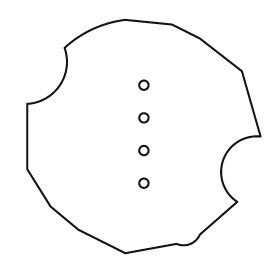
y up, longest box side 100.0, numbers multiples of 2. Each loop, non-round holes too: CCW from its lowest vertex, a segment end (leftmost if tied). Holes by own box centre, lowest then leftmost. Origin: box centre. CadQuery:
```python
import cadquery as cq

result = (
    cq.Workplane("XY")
    .moveTo(-8.0, -50.0)
    .lineTo(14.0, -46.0)
    .threePointArc((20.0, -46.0), (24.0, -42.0))
    .lineTo(40.0, -28.0)
    .threePointArc((34.0, -10.0), (50.0, 0.0))
    .lineTo(42.0, 28.0)
    .lineTo(24.0, 42.0)
    .lineTo(12.0, 48.0)
    .lineTo(-8.0, 50.0)
    .threePointArc((-22.0, 46.0), (-34.0, 38.0))
    .threePointArc((-36.0, 22.0), (-50.0, 14.0))
    .lineTo(-50.0, -14.0)
    .lineTo(-40.0, -30.0)
    .lineTo(-28.0, -40.0)
    .close()
    .moveTo(0.0, -20.0)
    .circle(2.0)
    .moveTo(0.0, -6.0)
    .circle(2.0)
    .moveTo(0.0, 8.0)
    .circle(2.0)
    .moveTo(0.0, 22.0)
    .circle(2.0)
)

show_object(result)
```